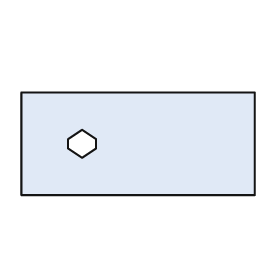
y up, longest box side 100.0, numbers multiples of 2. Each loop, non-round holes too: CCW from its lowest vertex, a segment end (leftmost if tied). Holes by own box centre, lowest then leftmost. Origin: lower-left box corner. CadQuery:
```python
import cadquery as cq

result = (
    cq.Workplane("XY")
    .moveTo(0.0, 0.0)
    .lineTo(100.0, 0.0)
    .lineTo(100.0, 44.0)
    .lineTo(0.0, 44.0)
    .close()
    .moveTo(26.0, 16.0)
    .lineTo(32.0, 20.0)
    .lineTo(32.0, 24.0)
    .lineTo(26.0, 28.0)
    .lineTo(20.0, 24.0)
    .lineTo(20.0, 20.0)
    .close()
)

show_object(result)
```